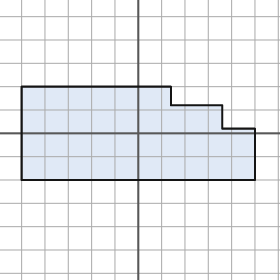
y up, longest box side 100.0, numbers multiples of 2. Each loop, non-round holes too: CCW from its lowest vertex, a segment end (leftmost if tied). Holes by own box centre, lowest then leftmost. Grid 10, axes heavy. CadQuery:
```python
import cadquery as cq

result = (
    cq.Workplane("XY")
    .moveTo(-50.0, -20.0)
    .lineTo(50.0, -20.0)
    .lineTo(50.0, 2.0)
    .lineTo(36.0, 2.0)
    .lineTo(36.0, 12.0)
    .lineTo(14.0, 12.0)
    .lineTo(14.0, 20.0)
    .lineTo(-50.0, 20.0)
    .close()
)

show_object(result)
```